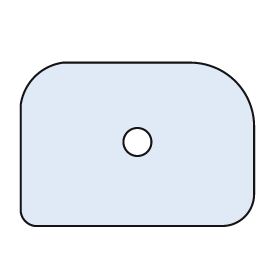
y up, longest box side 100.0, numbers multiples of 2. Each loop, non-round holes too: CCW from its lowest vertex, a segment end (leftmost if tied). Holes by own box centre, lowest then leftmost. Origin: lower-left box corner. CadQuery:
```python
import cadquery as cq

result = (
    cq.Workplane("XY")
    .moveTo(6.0, 0.0)
    .lineTo(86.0, 0.0)
    .threePointArc((96.0, 4.0), (100.0, 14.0))
    .lineTo(100.0, 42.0)
    .threePointArc((92.0, 62.0), (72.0, 70.0))
    .lineTo(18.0, 70.0)
    .threePointArc((6.0, 64.0), (0.0, 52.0))
    .lineTo(0.0, 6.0)
    .threePointArc((2.0, 2.0), (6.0, 0.0))
    .close()
    .moveTo(50.0, 36.0)
    .circle(6.0)
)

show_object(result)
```